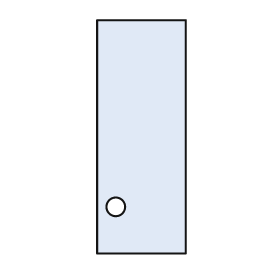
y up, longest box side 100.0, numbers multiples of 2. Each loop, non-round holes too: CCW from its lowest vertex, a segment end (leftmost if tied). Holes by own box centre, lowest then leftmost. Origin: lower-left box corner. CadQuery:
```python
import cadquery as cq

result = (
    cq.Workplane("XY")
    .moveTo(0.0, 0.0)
    .lineTo(38.0, 0.0)
    .lineTo(38.0, 100.0)
    .lineTo(0.0, 100.0)
    .close()
    .moveTo(8.0, 20.0)
    .circle(4.0)
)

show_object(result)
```